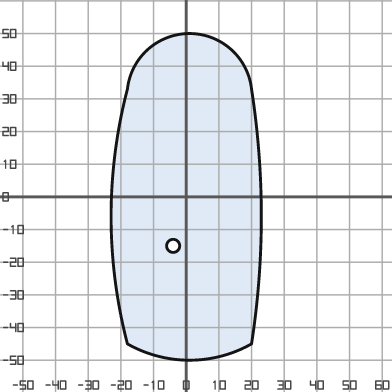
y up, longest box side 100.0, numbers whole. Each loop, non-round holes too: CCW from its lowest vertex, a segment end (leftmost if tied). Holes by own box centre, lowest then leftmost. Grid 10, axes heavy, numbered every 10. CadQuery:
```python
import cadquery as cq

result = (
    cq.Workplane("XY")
    .moveTo(-18.0, -45.0)
    .threePointArc((1.0, -50.0), (20.0, -45.0))
    .threePointArc((23.0, -6.0), (20.0, 33.0))
    .threePointArc((1.0, 50.0), (-18.0, 33.0))
    .threePointArc((-23.0, -6.0), (-18.0, -45.0))
    .close()
    .moveTo(-4.0, -15.0)
    .circle(2.0)
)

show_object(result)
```